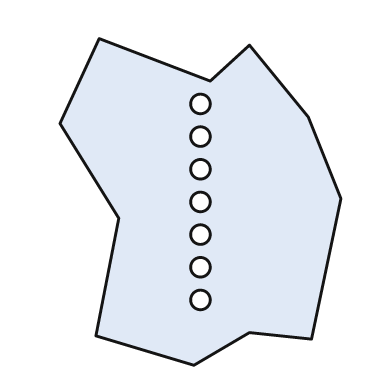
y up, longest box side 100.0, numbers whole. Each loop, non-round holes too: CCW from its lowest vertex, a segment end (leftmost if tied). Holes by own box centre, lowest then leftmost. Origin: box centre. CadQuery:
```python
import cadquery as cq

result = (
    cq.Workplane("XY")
    .moveTo(-2.0, -50.0)
    .lineTo(15.0, -40.0)
    .lineTo(34.0, -42.0)
    .lineTo(43.0, 1.0)
    .lineTo(33.0, 26.0)
    .lineTo(15.0, 48.0)
    .lineTo(3.0, 37.0)
    .lineTo(-31.0, 50.0)
    .lineTo(-43.0, 24.0)
    .lineTo(-25.0, -5.0)
    .lineTo(-32.0, -41.0)
    .close()
    .moveTo(0.0, -30.0)
    .circle(3.0)
    .moveTo(0.0, -20.0)
    .circle(3.0)
    .moveTo(0.0, -10.0)
    .circle(3.0)
    .moveTo(0.0, 0.0)
    .circle(3.0)
    .moveTo(0.0, 10.0)
    .circle(3.0)
    .moveTo(0.0, 20.0)
    .circle(3.0)
    .moveTo(0.0, 30.0)
    .circle(3.0)
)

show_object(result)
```